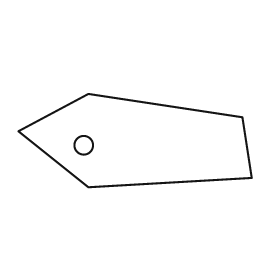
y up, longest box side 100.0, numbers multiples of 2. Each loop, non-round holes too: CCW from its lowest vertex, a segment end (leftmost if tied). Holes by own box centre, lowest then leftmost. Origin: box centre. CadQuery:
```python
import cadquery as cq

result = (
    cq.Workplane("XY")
    .moveTo(-20.0, -20.0)
    .lineTo(50.0, -16.0)
    .lineTo(46.0, 10.0)
    .lineTo(-20.0, 20.0)
    .lineTo(-50.0, 4.0)
    .close()
    .moveTo(-22.0, -2.0)
    .circle(4.0)
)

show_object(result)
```